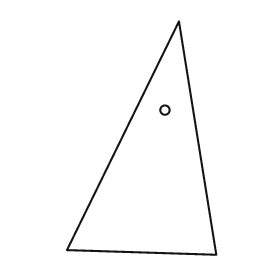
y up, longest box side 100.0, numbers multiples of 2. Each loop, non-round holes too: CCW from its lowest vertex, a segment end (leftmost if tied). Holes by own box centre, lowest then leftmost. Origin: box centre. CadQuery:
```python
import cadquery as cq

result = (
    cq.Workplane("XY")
    .moveTo(32.0, -50.0)
    .lineTo(16.0, 50.0)
    .lineTo(-32.0, -48.0)
    .close()
    .moveTo(10.0, 12.0)
    .circle(2.0)
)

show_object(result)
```